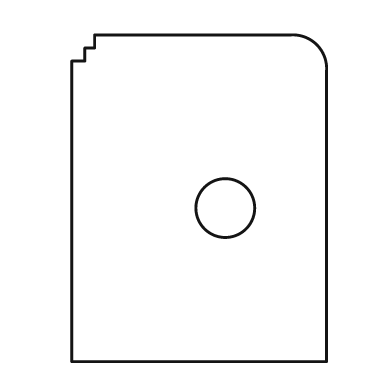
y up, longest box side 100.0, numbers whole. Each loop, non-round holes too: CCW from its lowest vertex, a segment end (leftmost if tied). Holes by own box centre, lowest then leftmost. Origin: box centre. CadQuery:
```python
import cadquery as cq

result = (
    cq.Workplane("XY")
    .moveTo(-39.0, -50.0)
    .lineTo(39.0, -50.0)
    .lineTo(39.0, 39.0)
    .threePointArc((36.0, 47.0), (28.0, 50.0))
    .lineTo(-32.0, 50.0)
    .lineTo(-32.0, 46.0)
    .lineTo(-35.0, 46.0)
    .lineTo(-35.0, 42.0)
    .lineTo(-39.0, 42.0)
    .close()
    .moveTo(8.0, -3.0)
    .circle(9.0)
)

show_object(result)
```